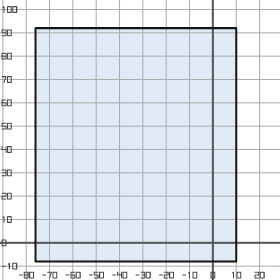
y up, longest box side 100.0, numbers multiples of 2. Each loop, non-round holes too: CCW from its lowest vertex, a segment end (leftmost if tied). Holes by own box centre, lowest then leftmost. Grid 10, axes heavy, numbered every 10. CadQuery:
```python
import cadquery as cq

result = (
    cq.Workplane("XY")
    .moveTo(-76.0, -8.0)
    .lineTo(10.0, -8.0)
    .lineTo(10.0, 92.0)
    .lineTo(-76.0, 92.0)
    .close()
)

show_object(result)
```